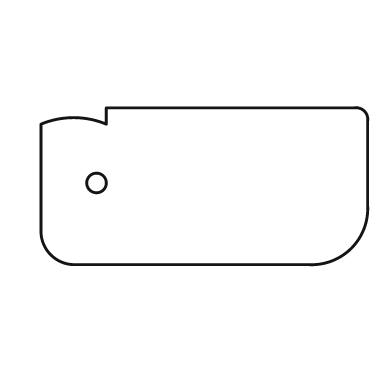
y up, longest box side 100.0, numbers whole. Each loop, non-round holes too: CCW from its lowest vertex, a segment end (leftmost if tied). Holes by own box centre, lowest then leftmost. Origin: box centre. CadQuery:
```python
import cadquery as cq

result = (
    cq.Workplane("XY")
    .moveTo(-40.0, -24.0)
    .lineTo(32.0, -24.0)
    .threePointArc((45.0, -19.0), (50.0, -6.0))
    .lineTo(50.0, 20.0)
    .threePointArc((49.0, 23.0), (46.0, 24.0))
    .lineTo(-30.0, 24.0)
    .lineTo(-30.0, 19.0)
    .threePointArc((-40.0, 21.0), (-50.0, 19.0))
    .lineTo(-50.0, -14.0)
    .threePointArc((-47.0, -21.0), (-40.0, -24.0))
    .close()
    .moveTo(-33.0, 1.0)
    .circle(3.0)
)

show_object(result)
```